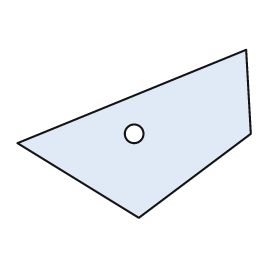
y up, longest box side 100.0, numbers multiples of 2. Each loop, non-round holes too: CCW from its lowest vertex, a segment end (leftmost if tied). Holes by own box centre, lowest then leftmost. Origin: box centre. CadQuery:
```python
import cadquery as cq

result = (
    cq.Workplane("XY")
    .moveTo(2.0, -36.0)
    .lineTo(50.0, 0.0)
    .lineTo(48.0, 36.0)
    .lineTo(-50.0, -4.0)
    .close()
    .moveTo(0.0, 0.0)
    .circle(4.0)
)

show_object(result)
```